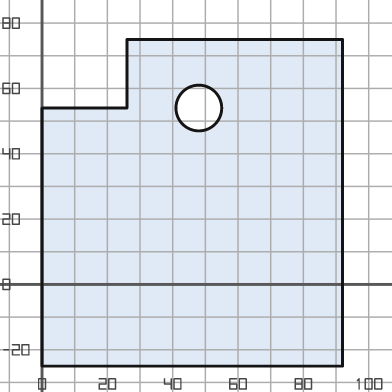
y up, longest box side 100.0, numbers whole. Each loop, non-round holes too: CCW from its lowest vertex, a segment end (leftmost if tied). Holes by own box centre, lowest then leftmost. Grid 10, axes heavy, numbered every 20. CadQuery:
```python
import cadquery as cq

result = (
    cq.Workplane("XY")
    .moveTo(0.0, -25.0)
    .lineTo(92.0, -25.0)
    .lineTo(92.0, 75.0)
    .lineTo(26.0, 75.0)
    .lineTo(26.0, 54.0)
    .lineTo(0.0, 54.0)
    .close()
    .moveTo(48.0, 54.0)
    .circle(7.0)
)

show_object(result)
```